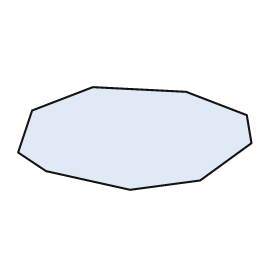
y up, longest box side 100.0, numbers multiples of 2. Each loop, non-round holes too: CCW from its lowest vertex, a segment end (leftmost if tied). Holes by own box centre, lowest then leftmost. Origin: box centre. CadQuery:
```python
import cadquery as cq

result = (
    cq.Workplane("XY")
    .moveTo(-2.0, -22.0)
    .lineTo(28.0, -18.0)
    .lineTo(50.0, -2.0)
    .lineTo(48.0, 10.0)
    .lineTo(22.0, 20.0)
    .lineTo(-18.0, 22.0)
    .lineTo(-44.0, 12.0)
    .lineTo(-50.0, -6.0)
    .lineTo(-38.0, -14.0)
    .close()
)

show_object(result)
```